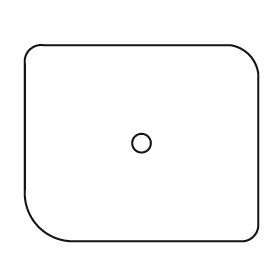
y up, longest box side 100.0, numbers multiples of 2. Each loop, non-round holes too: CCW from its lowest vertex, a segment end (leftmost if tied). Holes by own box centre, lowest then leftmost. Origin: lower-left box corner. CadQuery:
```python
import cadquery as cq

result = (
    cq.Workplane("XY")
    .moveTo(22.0, 0.0)
    .lineTo(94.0, 0.0)
    .threePointArc((98.0, 2.0), (100.0, 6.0))
    .lineTo(100.0, 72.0)
    .threePointArc((96.0, 80.0), (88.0, 84.0))
    .lineTo(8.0, 84.0)
    .threePointArc((2.0, 82.0), (0.0, 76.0))
    .lineTo(0.0, 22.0)
    .threePointArc((6.0, 6.0), (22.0, 0.0))
    .close()
    .moveTo(50.0, 42.0)
    .circle(4.0)
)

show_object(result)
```